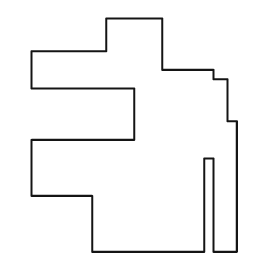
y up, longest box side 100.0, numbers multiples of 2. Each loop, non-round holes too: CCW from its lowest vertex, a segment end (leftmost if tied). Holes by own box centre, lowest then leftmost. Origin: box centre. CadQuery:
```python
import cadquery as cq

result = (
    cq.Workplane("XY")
    .moveTo(-18.0, -50.0)
    .lineTo(30.0, -50.0)
    .lineTo(30.0, -10.0)
    .lineTo(34.0, -10.0)
    .lineTo(34.0, -50.0)
    .lineTo(44.0, -50.0)
    .lineTo(44.0, 6.0)
    .lineTo(40.0, 6.0)
    .lineTo(40.0, 24.0)
    .lineTo(34.0, 24.0)
    .lineTo(34.0, 28.0)
    .lineTo(12.0, 28.0)
    .lineTo(12.0, 50.0)
    .lineTo(-12.0, 50.0)
    .lineTo(-12.0, 36.0)
    .lineTo(-44.0, 36.0)
    .lineTo(-44.0, 20.0)
    .lineTo(0.0, 20.0)
    .lineTo(0.0, -2.0)
    .lineTo(-44.0, -2.0)
    .lineTo(-44.0, -26.0)
    .lineTo(-18.0, -26.0)
    .close()
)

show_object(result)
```